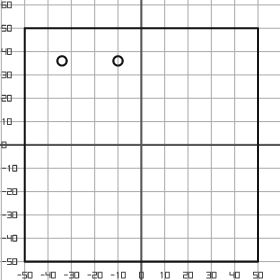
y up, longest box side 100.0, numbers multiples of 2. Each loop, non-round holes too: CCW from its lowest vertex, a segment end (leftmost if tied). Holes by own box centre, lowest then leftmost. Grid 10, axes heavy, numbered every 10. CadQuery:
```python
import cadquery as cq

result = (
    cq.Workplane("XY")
    .moveTo(-50.0, -50.0)
    .lineTo(50.0, -50.0)
    .lineTo(50.0, 50.0)
    .lineTo(-50.0, 50.0)
    .close()
    .moveTo(-34.0, 36.0)
    .circle(2.0)
    .moveTo(-10.0, 36.0)
    .circle(2.0)
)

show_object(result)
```